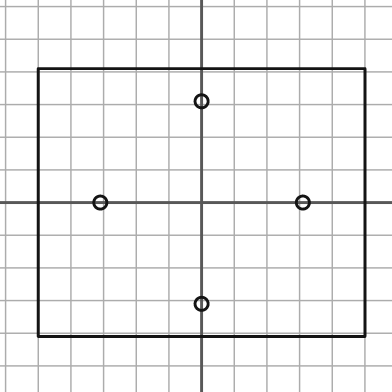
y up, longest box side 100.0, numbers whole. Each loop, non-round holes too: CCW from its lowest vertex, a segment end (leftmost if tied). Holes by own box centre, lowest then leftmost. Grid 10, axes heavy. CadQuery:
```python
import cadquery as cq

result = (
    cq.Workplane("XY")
    .moveTo(-50.0, -41.0)
    .lineTo(50.0, -41.0)
    .lineTo(50.0, 41.0)
    .lineTo(-50.0, 41.0)
    .close()
    .moveTo(0.0, -31.0)
    .circle(2.0)
    .moveTo(-31.0, 0.0)
    .circle(2.0)
    .moveTo(31.0, 0.0)
    .circle(2.0)
    .moveTo(0.0, 31.0)
    .circle(2.0)
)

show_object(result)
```